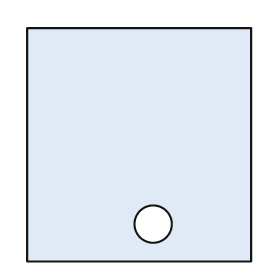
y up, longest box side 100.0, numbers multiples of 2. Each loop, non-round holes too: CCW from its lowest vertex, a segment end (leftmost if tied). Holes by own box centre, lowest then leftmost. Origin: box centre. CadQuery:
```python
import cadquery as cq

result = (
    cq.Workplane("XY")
    .moveTo(-48.0, -50.0)
    .lineTo(48.0, -50.0)
    .lineTo(48.0, 50.0)
    .lineTo(-48.0, 50.0)
    .close()
    .moveTo(6.0, -34.0)
    .circle(8.0)
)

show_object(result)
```